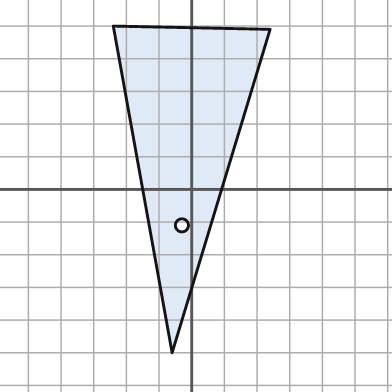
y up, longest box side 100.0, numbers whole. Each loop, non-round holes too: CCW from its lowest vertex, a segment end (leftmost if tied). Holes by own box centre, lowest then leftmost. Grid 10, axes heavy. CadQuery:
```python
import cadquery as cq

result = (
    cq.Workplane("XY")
    .moveTo(-6.0, -50.0)
    .lineTo(24.0, 49.0)
    .lineTo(-24.0, 50.0)
    .close()
    .moveTo(-3.0, -11.0)
    .circle(2.0)
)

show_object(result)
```